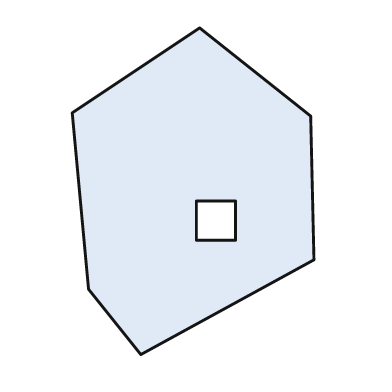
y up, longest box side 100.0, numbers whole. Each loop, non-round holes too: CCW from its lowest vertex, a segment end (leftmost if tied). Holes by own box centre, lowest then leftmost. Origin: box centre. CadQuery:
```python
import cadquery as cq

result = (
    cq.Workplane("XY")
    .moveTo(-16.0, -50.0)
    .lineTo(37.0, -21.0)
    .lineTo(36.0, 23.0)
    .lineTo(2.0, 50.0)
    .lineTo(-37.0, 24.0)
    .lineTo(-32.0, -30.0)
    .close()
    .moveTo(1.0, -15.0)
    .lineTo(13.0, -15.0)
    .lineTo(13.0, -3.0)
    .lineTo(1.0, -3.0)
    .close()
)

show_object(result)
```